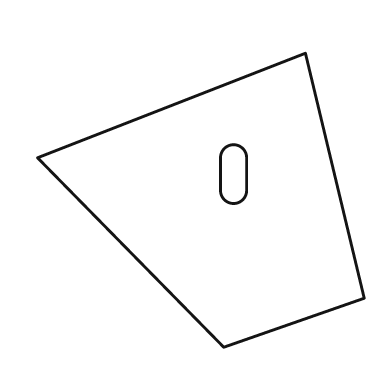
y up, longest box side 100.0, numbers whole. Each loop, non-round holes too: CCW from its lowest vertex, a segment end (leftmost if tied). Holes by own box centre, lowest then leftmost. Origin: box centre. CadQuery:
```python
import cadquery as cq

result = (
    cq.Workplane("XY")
    .moveTo(7.0, -45.0)
    .lineTo(50.0, -30.0)
    .lineTo(32.0, 45.0)
    .lineTo(-50.0, 13.0)
    .close()
    .moveTo(6.0, 3.0)
    .threePointArc((10.0, -1.0), (14.0, 3.0))
    .lineTo(14.0, 13.0)
    .threePointArc((10.0, 17.0), (6.0, 13.0))
    .close()
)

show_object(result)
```